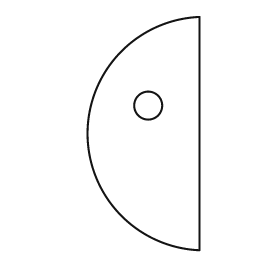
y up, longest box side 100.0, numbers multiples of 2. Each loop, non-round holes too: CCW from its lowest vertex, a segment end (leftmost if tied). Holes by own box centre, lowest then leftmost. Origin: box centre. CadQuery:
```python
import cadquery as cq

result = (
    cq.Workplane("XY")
    .moveTo(24.0, -50.0)
    .lineTo(24.0, 50.0)
    .threePointArc((-24.0, 0.0), (24.0, -50.0))
    .close()
    .moveTo(2.0, 12.0)
    .circle(6.0)
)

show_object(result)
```